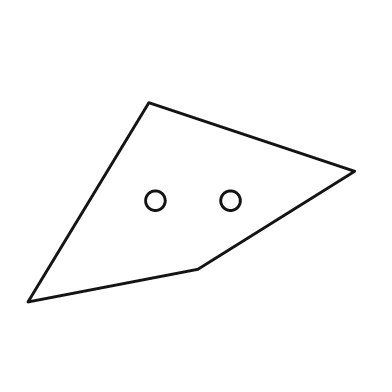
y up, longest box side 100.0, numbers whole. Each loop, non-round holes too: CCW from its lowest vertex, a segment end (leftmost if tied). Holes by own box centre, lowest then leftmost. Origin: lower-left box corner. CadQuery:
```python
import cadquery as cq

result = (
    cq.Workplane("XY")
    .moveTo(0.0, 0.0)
    .lineTo(52.0, 10.0)
    .lineTo(100.0, 40.0)
    .lineTo(37.0, 61.0)
    .close()
    .moveTo(39.0, 31.0)
    .circle(3.0)
    .moveTo(62.0, 31.0)
    .circle(3.0)
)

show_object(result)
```